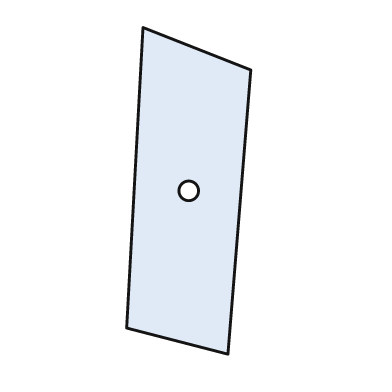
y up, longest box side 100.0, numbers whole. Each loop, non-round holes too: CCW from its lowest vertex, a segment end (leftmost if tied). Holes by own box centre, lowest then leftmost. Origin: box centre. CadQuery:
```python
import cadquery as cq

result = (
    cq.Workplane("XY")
    .moveTo(12.0, -50.0)
    .lineTo(19.0, 37.0)
    .lineTo(-14.0, 50.0)
    .lineTo(-19.0, -42.0)
    .close()
    .moveTo(0.0, 0.0)
    .circle(3.0)
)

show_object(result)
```